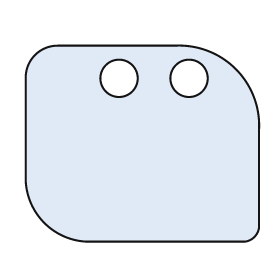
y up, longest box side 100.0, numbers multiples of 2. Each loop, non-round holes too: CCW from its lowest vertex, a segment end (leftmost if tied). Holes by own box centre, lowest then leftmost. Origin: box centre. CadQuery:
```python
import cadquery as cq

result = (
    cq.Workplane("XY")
    .moveTo(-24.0, -42.0)
    .lineTo(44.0, -42.0)
    .threePointArc((48.0, -40.0), (50.0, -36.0))
    .lineTo(50.0, 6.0)
    .threePointArc((40.0, 32.0), (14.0, 42.0))
    .lineTo(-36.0, 42.0)
    .threePointArc((-46.0, 38.0), (-50.0, 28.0))
    .lineTo(-50.0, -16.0)
    .threePointArc((-42.0, -34.0), (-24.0, -42.0))
    .close()
    .moveTo(-10.0, 28.0)
    .circle(8.0)
    .moveTo(20.0, 28.0)
    .circle(8.0)
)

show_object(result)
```